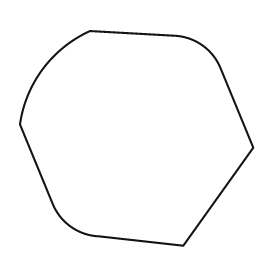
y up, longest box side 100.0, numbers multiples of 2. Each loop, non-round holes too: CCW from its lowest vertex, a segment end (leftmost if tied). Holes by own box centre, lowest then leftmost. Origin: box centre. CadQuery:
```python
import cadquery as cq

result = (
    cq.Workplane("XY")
    .moveTo(20.0, -46.0)
    .lineTo(50.0, -4.0)
    .lineTo(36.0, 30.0)
    .threePointArc((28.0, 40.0), (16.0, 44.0))
    .lineTo(-20.0, 46.0)
    .threePointArc((-40.0, 30.0), (-50.0, 6.0))
    .lineTo(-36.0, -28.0)
    .threePointArc((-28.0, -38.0), (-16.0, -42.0))
    .close()
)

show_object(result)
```